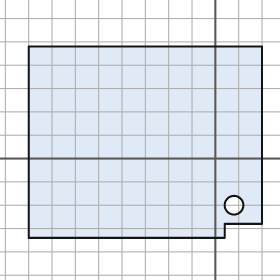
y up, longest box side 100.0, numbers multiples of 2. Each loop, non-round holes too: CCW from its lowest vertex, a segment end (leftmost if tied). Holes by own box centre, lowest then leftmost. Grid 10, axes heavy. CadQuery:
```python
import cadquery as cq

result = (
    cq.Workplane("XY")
    .moveTo(-80.0, -34.0)
    .lineTo(4.0, -34.0)
    .lineTo(4.0, -28.0)
    .lineTo(20.0, -28.0)
    .lineTo(20.0, 48.0)
    .lineTo(-80.0, 48.0)
    .close()
    .moveTo(8.0, -20.0)
    .circle(4.0)
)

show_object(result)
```